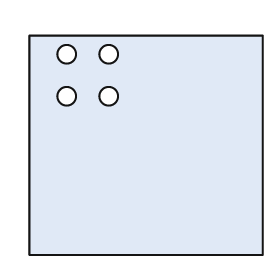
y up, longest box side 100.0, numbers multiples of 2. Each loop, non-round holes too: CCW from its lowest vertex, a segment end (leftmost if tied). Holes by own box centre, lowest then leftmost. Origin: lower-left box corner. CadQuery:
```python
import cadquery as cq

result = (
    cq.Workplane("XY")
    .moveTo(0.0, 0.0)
    .lineTo(100.0, 0.0)
    .lineTo(100.0, 94.0)
    .lineTo(0.0, 94.0)
    .close()
    .moveTo(16.0, 68.0)
    .circle(4.0)
    .moveTo(34.0, 68.0)
    .circle(4.0)
    .moveTo(16.0, 86.0)
    .circle(4.0)
    .moveTo(34.0, 86.0)
    .circle(4.0)
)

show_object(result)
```